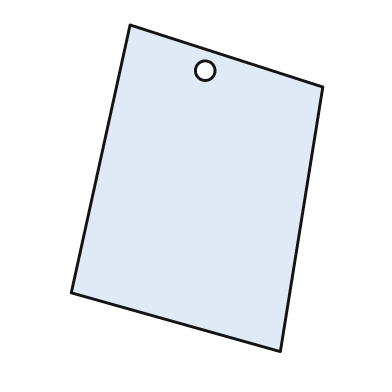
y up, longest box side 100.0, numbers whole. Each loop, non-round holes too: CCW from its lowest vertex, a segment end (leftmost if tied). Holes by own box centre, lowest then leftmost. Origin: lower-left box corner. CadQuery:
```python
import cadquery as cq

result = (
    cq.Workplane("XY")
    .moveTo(64.0, 0.0)
    .lineTo(77.0, 81.0)
    .lineTo(18.0, 100.0)
    .lineTo(0.0, 18.0)
    .close()
    .moveTo(41.0, 86.0)
    .circle(3.0)
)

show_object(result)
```